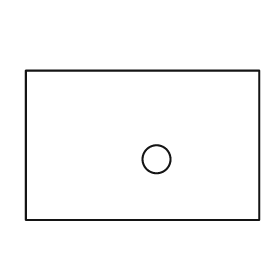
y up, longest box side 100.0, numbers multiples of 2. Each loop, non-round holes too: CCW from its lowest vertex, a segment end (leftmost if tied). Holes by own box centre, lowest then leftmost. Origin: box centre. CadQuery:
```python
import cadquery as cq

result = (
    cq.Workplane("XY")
    .moveTo(-50.0, -32.0)
    .lineTo(50.0, -32.0)
    .lineTo(50.0, 32.0)
    .lineTo(-50.0, 32.0)
    .close()
    .moveTo(6.0, -6.0)
    .circle(6.0)
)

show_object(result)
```